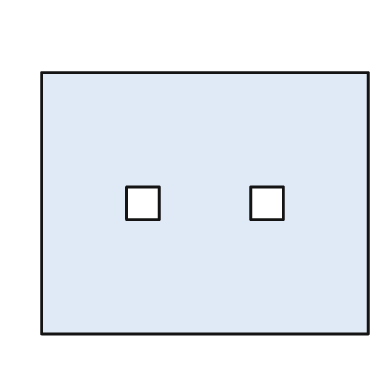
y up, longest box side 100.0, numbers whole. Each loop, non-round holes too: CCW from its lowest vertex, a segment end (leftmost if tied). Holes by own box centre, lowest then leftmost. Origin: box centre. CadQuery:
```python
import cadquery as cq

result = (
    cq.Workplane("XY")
    .moveTo(-50.0, -40.0)
    .lineTo(50.0, -40.0)
    .lineTo(50.0, 40.0)
    .lineTo(-50.0, 40.0)
    .close()
    .moveTo(-24.0, -5.0)
    .lineTo(-14.0, -5.0)
    .lineTo(-14.0, 5.0)
    .lineTo(-24.0, 5.0)
    .close()
    .moveTo(14.0, -5.0)
    .lineTo(24.0, -5.0)
    .lineTo(24.0, 5.0)
    .lineTo(14.0, 5.0)
    .close()
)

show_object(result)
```